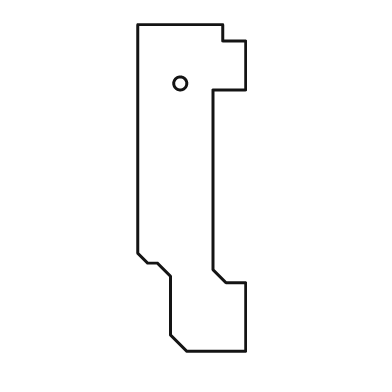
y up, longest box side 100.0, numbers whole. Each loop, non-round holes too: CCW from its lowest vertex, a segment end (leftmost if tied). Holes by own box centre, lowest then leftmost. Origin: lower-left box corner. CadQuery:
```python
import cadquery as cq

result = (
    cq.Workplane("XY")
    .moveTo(15.0, 0.0)
    .lineTo(33.0, 0.0)
    .lineTo(33.0, 21.0)
    .lineTo(27.0, 21.0)
    .lineTo(23.0, 25.0)
    .lineTo(23.0, 80.0)
    .lineTo(33.0, 80.0)
    .lineTo(33.0, 95.0)
    .lineTo(26.0, 95.0)
    .lineTo(26.0, 100.0)
    .lineTo(0.0, 100.0)
    .lineTo(0.0, 30.0)
    .lineTo(3.0, 27.0)
    .lineTo(6.0, 27.0)
    .lineTo(10.0, 23.0)
    .lineTo(10.0, 5.0)
    .close()
    .moveTo(13.0, 82.0)
    .circle(2.0)
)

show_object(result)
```